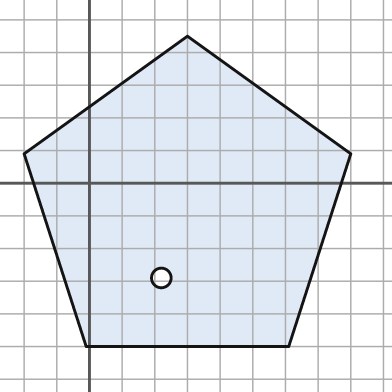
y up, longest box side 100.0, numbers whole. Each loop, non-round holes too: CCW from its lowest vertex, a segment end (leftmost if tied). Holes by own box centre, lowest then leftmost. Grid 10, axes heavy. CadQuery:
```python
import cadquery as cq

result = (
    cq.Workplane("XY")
    .moveTo(-1.0, -50.0)
    .lineTo(61.0, -50.0)
    .lineTo(80.0, 9.0)
    .lineTo(30.0, 45.0)
    .lineTo(-20.0, 9.0)
    .close()
    .moveTo(22.0, -29.0)
    .circle(3.0)
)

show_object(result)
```